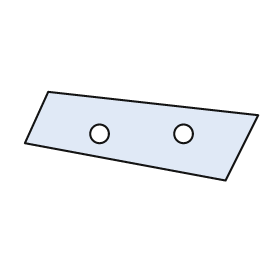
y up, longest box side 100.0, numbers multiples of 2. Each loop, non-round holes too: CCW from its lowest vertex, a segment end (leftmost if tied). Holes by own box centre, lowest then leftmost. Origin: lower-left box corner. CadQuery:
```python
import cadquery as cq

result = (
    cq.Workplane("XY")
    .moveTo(86.0, 0.0)
    .lineTo(100.0, 28.0)
    .lineTo(10.0, 38.0)
    .lineTo(0.0, 16.0)
    .close()
    .moveTo(32.0, 20.0)
    .circle(4.0)
    .moveTo(68.0, 20.0)
    .circle(4.0)
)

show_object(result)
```